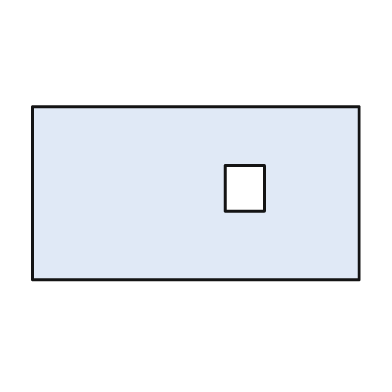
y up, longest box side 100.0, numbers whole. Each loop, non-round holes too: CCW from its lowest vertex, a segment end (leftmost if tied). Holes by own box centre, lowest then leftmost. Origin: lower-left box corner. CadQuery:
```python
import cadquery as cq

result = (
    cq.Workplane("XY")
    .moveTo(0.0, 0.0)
    .lineTo(100.0, 0.0)
    .lineTo(100.0, 53.0)
    .lineTo(0.0, 53.0)
    .close()
    .moveTo(59.0, 21.0)
    .lineTo(71.0, 21.0)
    .lineTo(71.0, 35.0)
    .lineTo(59.0, 35.0)
    .close()
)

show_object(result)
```